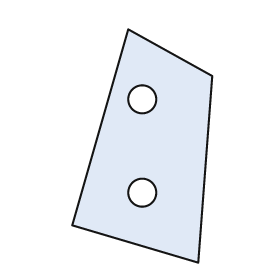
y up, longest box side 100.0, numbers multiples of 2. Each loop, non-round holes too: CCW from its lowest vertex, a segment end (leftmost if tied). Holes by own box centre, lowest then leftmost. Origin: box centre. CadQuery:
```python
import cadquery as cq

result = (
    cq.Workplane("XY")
    .moveTo(24.0, -50.0)
    .lineTo(30.0, 30.0)
    .lineTo(-6.0, 50.0)
    .lineTo(-30.0, -34.0)
    .close()
    .moveTo(0.0, -20.0)
    .circle(6.0)
    .moveTo(0.0, 20.0)
    .circle(6.0)
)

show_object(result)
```